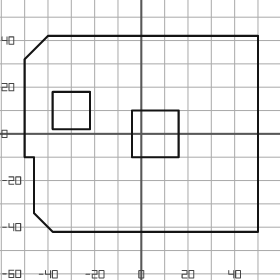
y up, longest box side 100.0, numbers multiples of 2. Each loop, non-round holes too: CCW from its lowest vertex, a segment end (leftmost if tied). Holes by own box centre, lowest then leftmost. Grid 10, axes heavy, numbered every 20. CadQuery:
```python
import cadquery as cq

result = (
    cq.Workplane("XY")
    .moveTo(-38.0, -42.0)
    .lineTo(50.0, -42.0)
    .lineTo(50.0, 42.0)
    .lineTo(-40.0, 42.0)
    .lineTo(-50.0, 32.0)
    .lineTo(-50.0, -10.0)
    .lineTo(-46.0, -10.0)
    .lineTo(-46.0, -34.0)
    .close()
    .moveTo(-4.0, -10.0)
    .lineTo(16.0, -10.0)
    .lineTo(16.0, 10.0)
    .lineTo(-4.0, 10.0)
    .close()
    .moveTo(-38.0, 2.0)
    .lineTo(-22.0, 2.0)
    .lineTo(-22.0, 18.0)
    .lineTo(-38.0, 18.0)
    .close()
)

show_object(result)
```